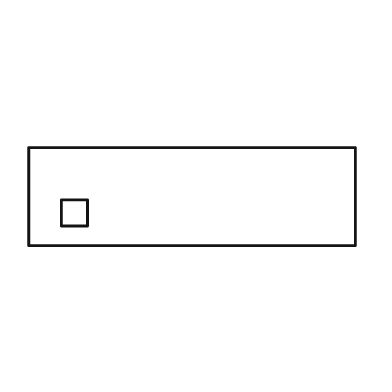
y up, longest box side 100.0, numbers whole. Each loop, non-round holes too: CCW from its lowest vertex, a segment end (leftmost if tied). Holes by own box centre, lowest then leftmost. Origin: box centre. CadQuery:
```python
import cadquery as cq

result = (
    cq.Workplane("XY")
    .moveTo(-50.0, -15.0)
    .lineTo(50.0, -15.0)
    .lineTo(50.0, 15.0)
    .lineTo(-50.0, 15.0)
    .close()
    .moveTo(-40.0, -9.0)
    .lineTo(-32.0, -9.0)
    .lineTo(-32.0, -1.0)
    .lineTo(-40.0, -1.0)
    .close()
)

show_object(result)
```